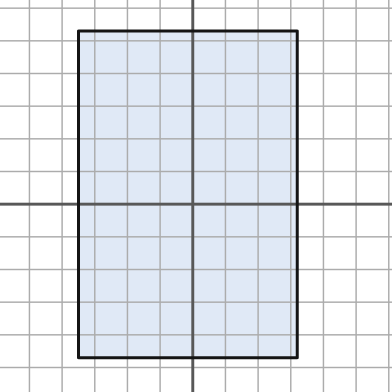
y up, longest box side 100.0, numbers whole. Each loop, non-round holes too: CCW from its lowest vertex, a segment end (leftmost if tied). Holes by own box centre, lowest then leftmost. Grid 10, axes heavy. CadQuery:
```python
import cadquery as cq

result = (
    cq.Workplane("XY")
    .moveTo(-35.0, -47.0)
    .lineTo(32.0, -47.0)
    .lineTo(32.0, 53.0)
    .lineTo(-35.0, 53.0)
    .close()
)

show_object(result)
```